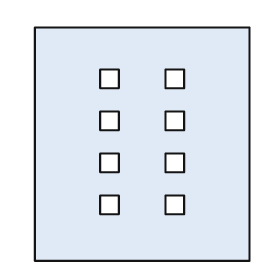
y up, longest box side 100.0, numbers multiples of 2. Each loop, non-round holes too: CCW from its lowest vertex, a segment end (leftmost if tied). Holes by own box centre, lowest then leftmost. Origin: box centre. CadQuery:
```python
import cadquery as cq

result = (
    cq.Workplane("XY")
    .moveTo(-46.0, -50.0)
    .lineTo(46.0, -50.0)
    .lineTo(46.0, 50.0)
    .lineTo(-46.0, 50.0)
    .close()
    .moveTo(-18.0, -30.0)
    .lineTo(-10.0, -30.0)
    .lineTo(-10.0, -22.0)
    .lineTo(-18.0, -22.0)
    .close()
    .moveTo(10.0, -30.0)
    .lineTo(18.0, -30.0)
    .lineTo(18.0, -22.0)
    .lineTo(10.0, -22.0)
    .close()
    .moveTo(-18.0, -12.0)
    .lineTo(-10.0, -12.0)
    .lineTo(-10.0, -4.0)
    .lineTo(-18.0, -4.0)
    .close()
    .moveTo(10.0, -12.0)
    .lineTo(18.0, -12.0)
    .lineTo(18.0, -4.0)
    .lineTo(10.0, -4.0)
    .close()
    .moveTo(-18.0, 6.0)
    .lineTo(-10.0, 6.0)
    .lineTo(-10.0, 14.0)
    .lineTo(-18.0, 14.0)
    .close()
    .moveTo(10.0, 6.0)
    .lineTo(18.0, 6.0)
    .lineTo(18.0, 14.0)
    .lineTo(10.0, 14.0)
    .close()
    .moveTo(-18.0, 24.0)
    .lineTo(-10.0, 24.0)
    .lineTo(-10.0, 32.0)
    .lineTo(-18.0, 32.0)
    .close()
    .moveTo(10.0, 24.0)
    .lineTo(18.0, 24.0)
    .lineTo(18.0, 32.0)
    .lineTo(10.0, 32.0)
    .close()
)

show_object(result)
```